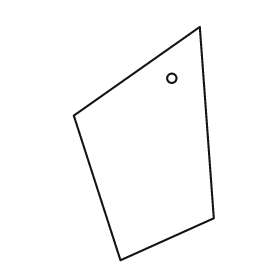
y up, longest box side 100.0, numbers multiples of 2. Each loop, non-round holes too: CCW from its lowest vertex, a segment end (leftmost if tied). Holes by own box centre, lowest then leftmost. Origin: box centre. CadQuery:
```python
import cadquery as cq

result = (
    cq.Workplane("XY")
    .moveTo(-10.0, -50.0)
    .lineTo(30.0, -32.0)
    .lineTo(24.0, 50.0)
    .lineTo(-30.0, 12.0)
    .close()
    .moveTo(12.0, 28.0)
    .circle(2.0)
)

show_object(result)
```